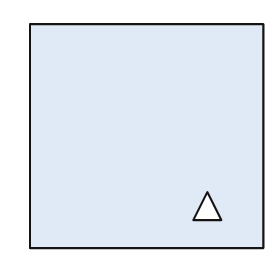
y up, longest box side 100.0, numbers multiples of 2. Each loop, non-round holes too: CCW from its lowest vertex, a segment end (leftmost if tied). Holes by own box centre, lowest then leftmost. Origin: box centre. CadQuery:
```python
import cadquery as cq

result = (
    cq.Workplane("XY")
    .moveTo(-50.0, -48.0)
    .lineTo(50.0, -48.0)
    .lineTo(50.0, 48.0)
    .lineTo(-50.0, 48.0)
    .close()
    .moveTo(20.0, -36.0)
    .lineTo(32.0, -36.0)
    .lineTo(26.0, -24.0)
    .close()
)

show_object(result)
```